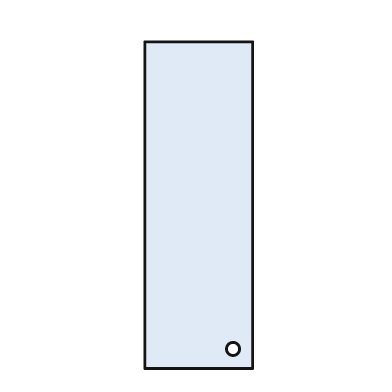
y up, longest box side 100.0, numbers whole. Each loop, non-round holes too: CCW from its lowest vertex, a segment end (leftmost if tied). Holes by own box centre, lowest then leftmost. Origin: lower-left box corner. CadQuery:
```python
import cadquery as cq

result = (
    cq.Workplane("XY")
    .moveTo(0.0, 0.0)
    .lineTo(33.0, 0.0)
    .lineTo(33.0, 100.0)
    .lineTo(0.0, 100.0)
    .close()
    .moveTo(27.0, 6.0)
    .circle(2.0)
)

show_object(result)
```